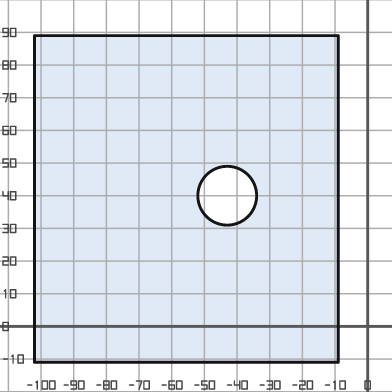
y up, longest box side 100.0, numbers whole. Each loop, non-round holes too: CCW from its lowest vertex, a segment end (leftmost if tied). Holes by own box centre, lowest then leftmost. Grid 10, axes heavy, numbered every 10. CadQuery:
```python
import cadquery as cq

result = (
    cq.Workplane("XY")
    .moveTo(-102.0, -11.0)
    .lineTo(-9.0, -11.0)
    .lineTo(-9.0, 89.0)
    .lineTo(-102.0, 89.0)
    .close()
    .moveTo(-43.0, 40.0)
    .circle(9.0)
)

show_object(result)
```